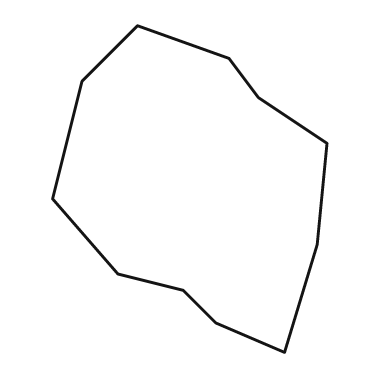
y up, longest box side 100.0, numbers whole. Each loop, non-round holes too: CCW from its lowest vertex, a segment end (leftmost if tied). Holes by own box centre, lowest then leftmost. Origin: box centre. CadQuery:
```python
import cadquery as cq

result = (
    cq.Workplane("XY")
    .moveTo(29.0, -50.0)
    .lineTo(39.0, -17.0)
    .lineTo(42.0, 14.0)
    .lineTo(21.0, 28.0)
    .lineTo(12.0, 40.0)
    .lineTo(-16.0, 50.0)
    .lineTo(-33.0, 33.0)
    .lineTo(-42.0, -3.0)
    .lineTo(-22.0, -26.0)
    .lineTo(-2.0, -31.0)
    .lineTo(8.0, -41.0)
    .close()
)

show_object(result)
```